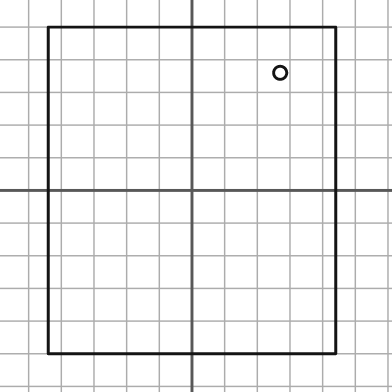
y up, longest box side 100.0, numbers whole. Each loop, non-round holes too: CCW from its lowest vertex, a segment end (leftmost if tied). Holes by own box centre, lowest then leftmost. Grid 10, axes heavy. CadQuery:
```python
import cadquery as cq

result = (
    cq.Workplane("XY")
    .moveTo(-44.0, -50.0)
    .lineTo(44.0, -50.0)
    .lineTo(44.0, 50.0)
    .lineTo(-44.0, 50.0)
    .close()
    .moveTo(27.0, 36.0)
    .circle(2.0)
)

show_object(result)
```